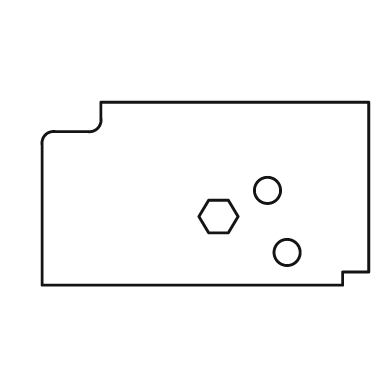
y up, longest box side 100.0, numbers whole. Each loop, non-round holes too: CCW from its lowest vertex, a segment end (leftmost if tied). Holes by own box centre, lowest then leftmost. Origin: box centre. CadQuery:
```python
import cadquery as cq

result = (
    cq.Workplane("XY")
    .moveTo(-50.0, -28.0)
    .lineTo(42.0, -28.0)
    .lineTo(42.0, -24.0)
    .lineTo(50.0, -24.0)
    .lineTo(50.0, 28.0)
    .lineTo(-32.0, 28.0)
    .lineTo(-32.0, 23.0)
    .threePointArc((-33.0, 20.0), (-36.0, 19.0))
    .lineTo(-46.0, 19.0)
    .threePointArc((-49.0, 18.0), (-50.0, 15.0))
    .close()
    .moveTo(25.0, -18.0)
    .circle(4.0)
    .moveTo(1.0, -12.0)
    .lineTo(7.0, -12.0)
    .lineTo(10.0, -7.0)
    .lineTo(7.0, -2.0)
    .lineTo(1.0, -2.0)
    .lineTo(-2.0, -7.0)
    .close()
    .moveTo(19.0, 1.0)
    .circle(4.0)
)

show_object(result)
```